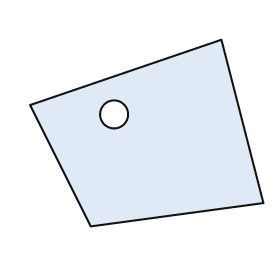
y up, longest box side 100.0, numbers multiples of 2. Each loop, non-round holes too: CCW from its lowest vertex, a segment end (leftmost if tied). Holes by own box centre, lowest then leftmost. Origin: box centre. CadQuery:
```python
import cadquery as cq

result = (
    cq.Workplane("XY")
    .moveTo(-24.0, -40.0)
    .lineTo(50.0, -30.0)
    .lineTo(32.0, 40.0)
    .lineTo(-50.0, 12.0)
    .close()
    .moveTo(-14.0, 8.0)
    .circle(6.0)
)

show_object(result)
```